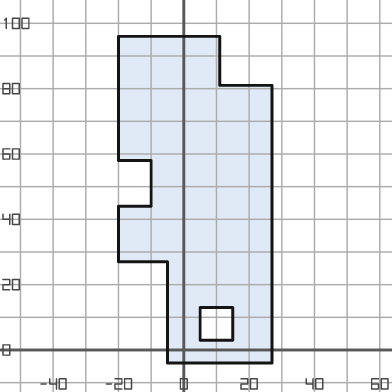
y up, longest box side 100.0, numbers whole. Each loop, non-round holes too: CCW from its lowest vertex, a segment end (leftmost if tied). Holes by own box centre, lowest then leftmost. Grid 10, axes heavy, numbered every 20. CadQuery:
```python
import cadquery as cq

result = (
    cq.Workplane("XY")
    .moveTo(-5.0, -4.0)
    .lineTo(27.0, -4.0)
    .lineTo(27.0, 81.0)
    .lineTo(11.0, 81.0)
    .lineTo(11.0, 96.0)
    .lineTo(-20.0, 96.0)
    .lineTo(-20.0, 58.0)
    .lineTo(-10.0, 58.0)
    .lineTo(-10.0, 44.0)
    .lineTo(-20.0, 44.0)
    .lineTo(-20.0, 27.0)
    .lineTo(-5.0, 27.0)
    .close()
    .moveTo(5.0, 3.0)
    .lineTo(15.0, 3.0)
    .lineTo(15.0, 13.0)
    .lineTo(5.0, 13.0)
    .close()
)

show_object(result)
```